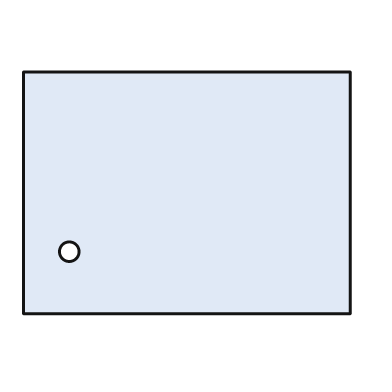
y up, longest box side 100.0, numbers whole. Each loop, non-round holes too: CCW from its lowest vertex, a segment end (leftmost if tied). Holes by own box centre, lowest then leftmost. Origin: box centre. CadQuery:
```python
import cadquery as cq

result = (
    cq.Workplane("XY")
    .moveTo(-50.0, -37.0)
    .lineTo(50.0, -37.0)
    .lineTo(50.0, 37.0)
    .lineTo(-50.0, 37.0)
    .close()
    .moveTo(-36.0, -18.0)
    .circle(3.0)
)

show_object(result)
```